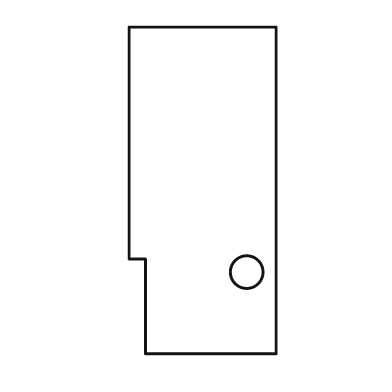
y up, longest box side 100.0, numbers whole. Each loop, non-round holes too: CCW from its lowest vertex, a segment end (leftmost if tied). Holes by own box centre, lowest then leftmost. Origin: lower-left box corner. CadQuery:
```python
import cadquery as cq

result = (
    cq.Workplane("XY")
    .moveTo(5.0, 0.0)
    .lineTo(45.0, 0.0)
    .lineTo(45.0, 100.0)
    .lineTo(0.0, 100.0)
    .lineTo(0.0, 29.0)
    .lineTo(5.0, 29.0)
    .close()
    .moveTo(36.0, 25.0)
    .circle(5.0)
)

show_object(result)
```